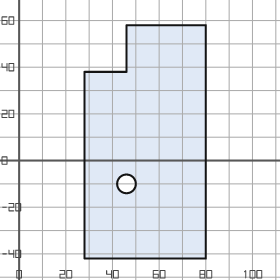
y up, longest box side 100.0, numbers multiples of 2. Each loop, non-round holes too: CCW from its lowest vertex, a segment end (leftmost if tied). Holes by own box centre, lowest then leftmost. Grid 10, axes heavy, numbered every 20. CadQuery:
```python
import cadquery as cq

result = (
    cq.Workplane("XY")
    .moveTo(28.0, -42.0)
    .lineTo(80.0, -42.0)
    .lineTo(80.0, 58.0)
    .lineTo(46.0, 58.0)
    .lineTo(46.0, 38.0)
    .lineTo(28.0, 38.0)
    .close()
    .moveTo(46.0, -10.0)
    .circle(4.0)
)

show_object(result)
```